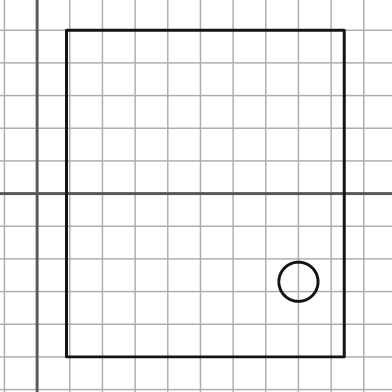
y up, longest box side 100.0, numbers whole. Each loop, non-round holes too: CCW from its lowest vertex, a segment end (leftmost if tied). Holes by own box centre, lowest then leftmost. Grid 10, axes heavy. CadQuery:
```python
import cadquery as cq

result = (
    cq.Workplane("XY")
    .moveTo(9.0, -50.0)
    .lineTo(94.0, -50.0)
    .lineTo(94.0, 50.0)
    .lineTo(9.0, 50.0)
    .close()
    .moveTo(80.0, -27.0)
    .circle(6.0)
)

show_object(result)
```